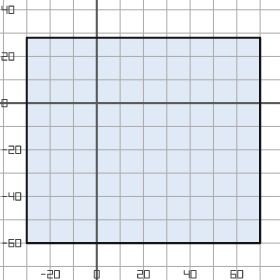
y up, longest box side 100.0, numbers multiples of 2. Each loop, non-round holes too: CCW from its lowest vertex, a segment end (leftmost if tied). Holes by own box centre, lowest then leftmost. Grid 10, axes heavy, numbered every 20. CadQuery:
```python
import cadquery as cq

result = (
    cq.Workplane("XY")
    .moveTo(-30.0, -60.0)
    .lineTo(70.0, -60.0)
    .lineTo(70.0, 28.0)
    .lineTo(-30.0, 28.0)
    .close()
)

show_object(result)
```